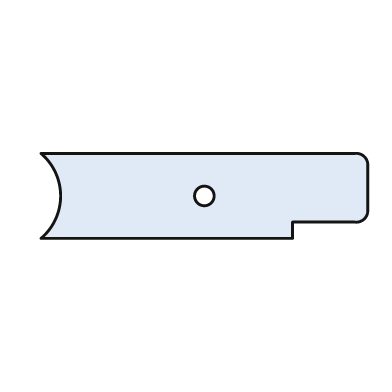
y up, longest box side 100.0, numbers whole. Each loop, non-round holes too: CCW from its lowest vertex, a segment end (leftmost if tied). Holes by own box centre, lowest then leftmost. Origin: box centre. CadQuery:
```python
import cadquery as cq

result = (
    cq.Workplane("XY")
    .moveTo(-50.0, -13.0)
    .lineTo(27.0, -13.0)
    .lineTo(27.0, -8.0)
    .lineTo(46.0, -8.0)
    .threePointArc((49.0, -7.0), (50.0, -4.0))
    .lineTo(50.0, 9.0)
    .threePointArc((49.0, 12.0), (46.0, 13.0))
    .lineTo(-50.0, 13.0)
    .threePointArc((-44.0, 0.0), (-50.0, -13.0))
    .close()
    .moveTo(0.0, 0.0)
    .circle(3.0)
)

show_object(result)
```